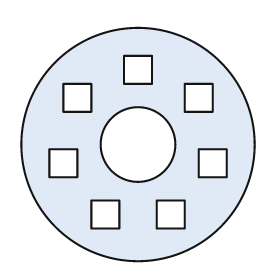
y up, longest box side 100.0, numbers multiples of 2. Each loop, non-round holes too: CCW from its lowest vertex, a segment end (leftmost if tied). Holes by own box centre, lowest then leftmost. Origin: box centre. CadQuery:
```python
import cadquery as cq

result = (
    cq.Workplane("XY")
    .moveTo(0.0, 0.0)
    .circle(50.0)
    .moveTo(-20.0, -36.0)
    .lineTo(-8.0, -36.0)
    .lineTo(-8.0, -24.0)
    .lineTo(-20.0, -24.0)
    .close()
    .moveTo(8.0, -36.0)
    .lineTo(20.0, -36.0)
    .lineTo(20.0, -24.0)
    .lineTo(8.0, -24.0)
    .close()
    .moveTo(-38.0, -14.0)
    .lineTo(-26.0, -14.0)
    .lineTo(-26.0, -2.0)
    .lineTo(-38.0, -2.0)
    .close()
    .moveTo(26.0, -14.0)
    .lineTo(38.0, -14.0)
    .lineTo(38.0, -2.0)
    .lineTo(26.0, -2.0)
    .close()
    .moveTo(0.0, 0.0)
    .circle(16.0)
    .moveTo(-32.0, 14.0)
    .lineTo(-20.0, 14.0)
    .lineTo(-20.0, 26.0)
    .lineTo(-32.0, 26.0)
    .close()
    .moveTo(20.0, 14.0)
    .lineTo(32.0, 14.0)
    .lineTo(32.0, 26.0)
    .lineTo(20.0, 26.0)
    .close()
    .moveTo(-6.0, 26.0)
    .lineTo(6.0, 26.0)
    .lineTo(6.0, 38.0)
    .lineTo(-6.0, 38.0)
    .close()
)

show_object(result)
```